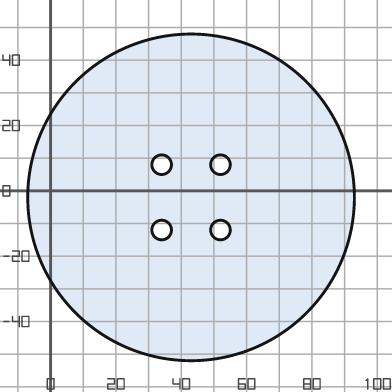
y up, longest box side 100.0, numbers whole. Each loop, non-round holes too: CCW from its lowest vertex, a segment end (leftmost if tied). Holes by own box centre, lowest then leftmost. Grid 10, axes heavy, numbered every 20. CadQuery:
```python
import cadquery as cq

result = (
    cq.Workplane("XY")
    .moveTo(43.0, -2.0)
    .circle(50.0)
    .moveTo(34.0, -12.0)
    .circle(3.0)
    .moveTo(52.0, -12.0)
    .circle(3.0)
    .moveTo(34.0, 8.0)
    .circle(3.0)
    .moveTo(52.0, 8.0)
    .circle(3.0)
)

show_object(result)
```